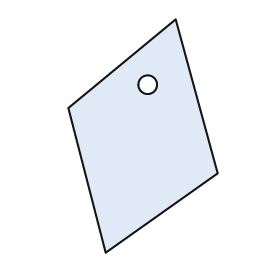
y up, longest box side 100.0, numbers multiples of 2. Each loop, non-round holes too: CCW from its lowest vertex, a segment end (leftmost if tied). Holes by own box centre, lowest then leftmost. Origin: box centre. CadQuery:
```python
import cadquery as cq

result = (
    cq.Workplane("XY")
    .moveTo(-16.0, -50.0)
    .lineTo(32.0, -16.0)
    .lineTo(14.0, 50.0)
    .lineTo(-32.0, 12.0)
    .close()
    .moveTo(2.0, 22.0)
    .circle(4.0)
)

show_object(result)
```